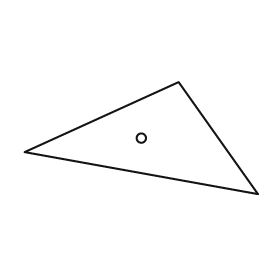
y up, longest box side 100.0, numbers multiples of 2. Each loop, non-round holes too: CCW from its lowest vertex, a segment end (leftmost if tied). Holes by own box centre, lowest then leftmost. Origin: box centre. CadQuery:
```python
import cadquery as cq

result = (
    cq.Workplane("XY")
    .moveTo(50.0, -24.0)
    .lineTo(16.0, 24.0)
    .lineTo(-50.0, -6.0)
    .close()
    .moveTo(0.0, 0.0)
    .circle(2.0)
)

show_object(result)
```